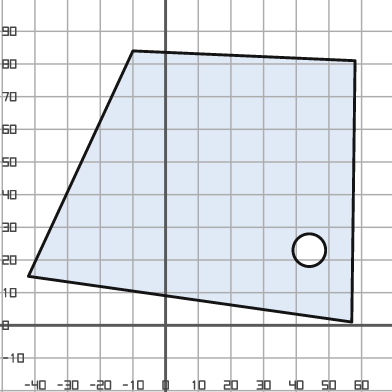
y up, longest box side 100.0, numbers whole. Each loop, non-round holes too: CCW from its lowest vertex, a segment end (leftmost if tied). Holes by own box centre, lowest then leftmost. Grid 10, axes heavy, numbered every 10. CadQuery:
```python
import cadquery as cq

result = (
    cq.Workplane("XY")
    .moveTo(57.0, 1.0)
    .lineTo(58.0, 81.0)
    .lineTo(-10.0, 84.0)
    .lineTo(-42.0, 15.0)
    .close()
    .moveTo(44.0, 23.0)
    .circle(5.0)
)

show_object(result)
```